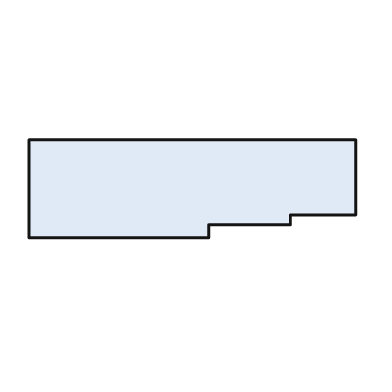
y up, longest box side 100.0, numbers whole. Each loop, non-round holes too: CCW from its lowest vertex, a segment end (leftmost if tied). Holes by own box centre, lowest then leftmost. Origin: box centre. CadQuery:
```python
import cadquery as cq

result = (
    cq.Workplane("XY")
    .moveTo(-50.0, -15.0)
    .lineTo(5.0, -15.0)
    .lineTo(5.0, -11.0)
    .lineTo(30.0, -11.0)
    .lineTo(30.0, -8.0)
    .lineTo(50.0, -8.0)
    .lineTo(50.0, 15.0)
    .lineTo(-50.0, 15.0)
    .close()
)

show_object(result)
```